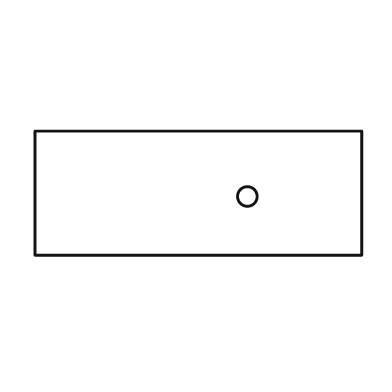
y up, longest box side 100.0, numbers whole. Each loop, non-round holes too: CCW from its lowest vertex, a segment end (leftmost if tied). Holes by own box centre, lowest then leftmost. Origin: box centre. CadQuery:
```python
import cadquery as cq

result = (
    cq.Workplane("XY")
    .moveTo(-50.0, -19.0)
    .lineTo(50.0, -19.0)
    .lineTo(50.0, 19.0)
    .lineTo(-50.0, 19.0)
    .close()
    .moveTo(15.0, -1.0)
    .circle(3.0)
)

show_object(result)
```